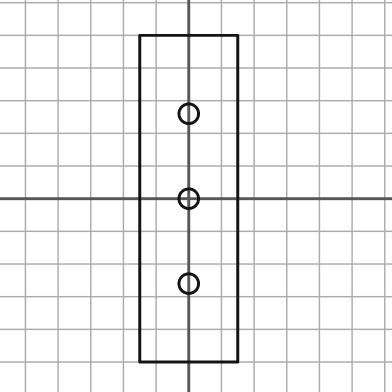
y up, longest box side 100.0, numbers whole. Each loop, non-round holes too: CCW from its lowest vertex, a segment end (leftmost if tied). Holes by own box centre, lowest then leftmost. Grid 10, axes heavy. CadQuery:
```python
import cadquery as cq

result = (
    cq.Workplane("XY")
    .moveTo(-15.0, -50.0)
    .lineTo(15.0, -50.0)
    .lineTo(15.0, 50.0)
    .lineTo(-15.0, 50.0)
    .close()
    .moveTo(0.0, -26.0)
    .circle(3.0)
    .moveTo(0.0, 0.0)
    .circle(3.0)
    .moveTo(0.0, 26.0)
    .circle(3.0)
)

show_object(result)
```